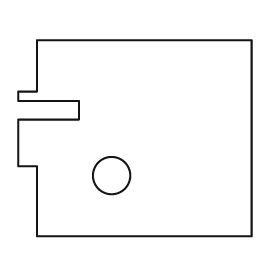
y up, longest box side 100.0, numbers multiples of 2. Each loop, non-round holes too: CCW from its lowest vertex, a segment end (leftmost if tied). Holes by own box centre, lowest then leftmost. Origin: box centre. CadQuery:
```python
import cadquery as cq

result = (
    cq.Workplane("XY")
    .moveTo(-42.0, -42.0)
    .lineTo(50.0, -42.0)
    .lineTo(50.0, 42.0)
    .lineTo(-42.0, 42.0)
    .lineTo(-42.0, 20.0)
    .lineTo(-50.0, 20.0)
    .lineTo(-50.0, 16.0)
    .lineTo(-24.0, 16.0)
    .lineTo(-24.0, 8.0)
    .lineTo(-50.0, 8.0)
    .lineTo(-50.0, -12.0)
    .lineTo(-42.0, -12.0)
    .close()
    .moveTo(-10.0, -16.0)
    .circle(8.0)
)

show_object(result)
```